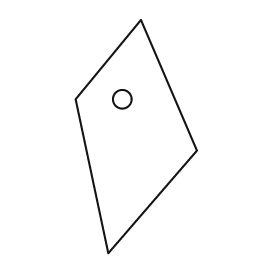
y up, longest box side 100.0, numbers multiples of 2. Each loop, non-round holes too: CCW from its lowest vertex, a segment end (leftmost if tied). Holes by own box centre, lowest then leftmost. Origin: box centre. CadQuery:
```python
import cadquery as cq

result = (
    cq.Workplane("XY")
    .moveTo(-12.0, -50.0)
    .lineTo(26.0, -6.0)
    .lineTo(2.0, 50.0)
    .lineTo(-26.0, 16.0)
    .close()
    .moveTo(-6.0, 16.0)
    .circle(4.0)
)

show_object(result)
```